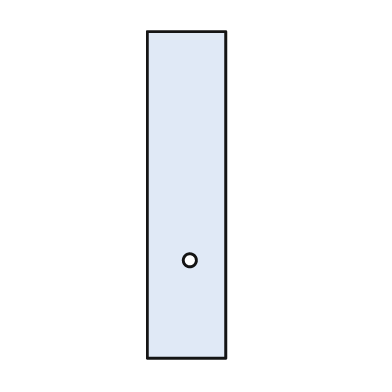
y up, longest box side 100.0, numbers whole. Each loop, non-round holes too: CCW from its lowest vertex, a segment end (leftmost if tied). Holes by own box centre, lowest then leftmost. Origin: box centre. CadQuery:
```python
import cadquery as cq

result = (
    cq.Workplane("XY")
    .moveTo(-12.0, -50.0)
    .lineTo(12.0, -50.0)
    .lineTo(12.0, 50.0)
    .lineTo(-12.0, 50.0)
    .close()
    .moveTo(1.0, -20.0)
    .circle(2.0)
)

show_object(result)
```